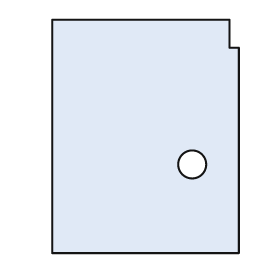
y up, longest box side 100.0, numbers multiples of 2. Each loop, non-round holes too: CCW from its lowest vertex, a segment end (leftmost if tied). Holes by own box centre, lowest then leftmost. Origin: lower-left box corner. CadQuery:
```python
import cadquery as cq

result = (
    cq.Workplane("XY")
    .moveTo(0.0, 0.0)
    .lineTo(80.0, 0.0)
    .lineTo(80.0, 88.0)
    .lineTo(76.0, 88.0)
    .lineTo(76.0, 100.0)
    .lineTo(0.0, 100.0)
    .close()
    .moveTo(60.0, 38.0)
    .circle(6.0)
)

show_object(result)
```